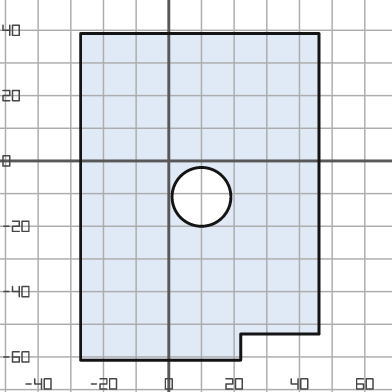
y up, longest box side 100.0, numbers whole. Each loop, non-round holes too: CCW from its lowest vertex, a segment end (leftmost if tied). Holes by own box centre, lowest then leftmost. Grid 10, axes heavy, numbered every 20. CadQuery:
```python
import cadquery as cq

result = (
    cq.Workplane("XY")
    .moveTo(-27.0, -61.0)
    .lineTo(22.0, -61.0)
    .lineTo(22.0, -53.0)
    .lineTo(46.0, -53.0)
    .lineTo(46.0, 39.0)
    .lineTo(-27.0, 39.0)
    .close()
    .moveTo(10.0, -11.0)
    .circle(9.0)
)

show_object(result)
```